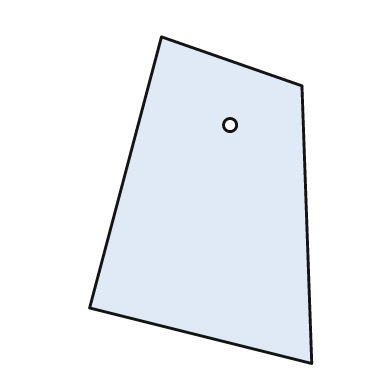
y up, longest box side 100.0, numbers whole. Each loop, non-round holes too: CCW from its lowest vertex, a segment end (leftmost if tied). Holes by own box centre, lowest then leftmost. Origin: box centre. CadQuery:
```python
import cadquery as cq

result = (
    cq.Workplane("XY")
    .moveTo(34.0, -50.0)
    .lineTo(31.0, 35.0)
    .lineTo(-12.0, 50.0)
    .lineTo(-34.0, -33.0)
    .close()
    .moveTo(9.0, 23.0)
    .circle(2.0)
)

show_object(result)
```